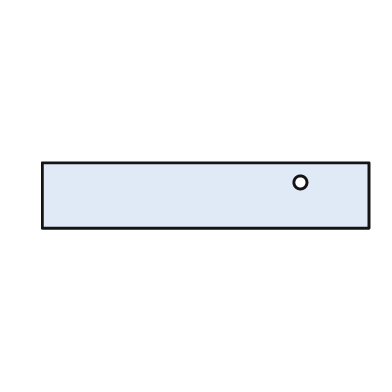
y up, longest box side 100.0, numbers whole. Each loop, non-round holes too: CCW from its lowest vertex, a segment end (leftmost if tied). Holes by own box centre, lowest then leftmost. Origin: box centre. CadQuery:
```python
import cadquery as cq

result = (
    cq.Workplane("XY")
    .moveTo(-50.0, -10.0)
    .lineTo(50.0, -10.0)
    .lineTo(50.0, 10.0)
    .lineTo(-50.0, 10.0)
    .close()
    .moveTo(29.0, 4.0)
    .circle(2.0)
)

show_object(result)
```